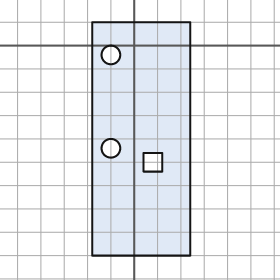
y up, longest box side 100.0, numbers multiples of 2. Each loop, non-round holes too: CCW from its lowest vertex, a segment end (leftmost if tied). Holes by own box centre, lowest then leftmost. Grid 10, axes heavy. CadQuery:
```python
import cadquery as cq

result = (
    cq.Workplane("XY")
    .moveTo(-18.0, -90.0)
    .lineTo(24.0, -90.0)
    .lineTo(24.0, 10.0)
    .lineTo(-18.0, 10.0)
    .close()
    .moveTo(4.0, -54.0)
    .lineTo(12.0, -54.0)
    .lineTo(12.0, -46.0)
    .lineTo(4.0, -46.0)
    .close()
    .moveTo(-10.0, -44.0)
    .circle(4.0)
    .moveTo(-10.0, -4.0)
    .circle(4.0)
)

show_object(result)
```